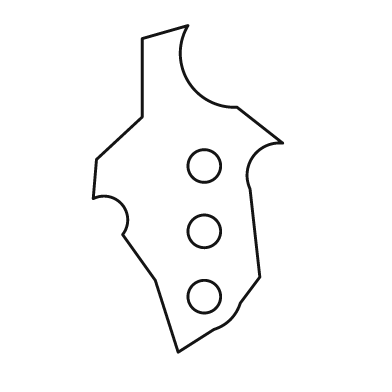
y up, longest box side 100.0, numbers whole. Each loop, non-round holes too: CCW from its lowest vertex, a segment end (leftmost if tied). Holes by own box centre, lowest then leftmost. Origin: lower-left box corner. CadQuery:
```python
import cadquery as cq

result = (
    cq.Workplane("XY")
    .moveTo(26.0, 0.0)
    .lineTo(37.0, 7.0)
    .threePointArc((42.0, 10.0), (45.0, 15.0))
    .lineTo(51.0, 23.0)
    .lineTo(48.0, 50.0)
    .threePointArc((49.0, 60.0), (58.0, 64.0))
    .lineTo(44.0, 75.0)
    .threePointArc((29.0, 83.0), (29.0, 100.0))
    .lineTo(15.0, 96.0)
    .lineTo(15.0, 72.0)
    .lineTo(1.0, 59.0)
    .lineTo(0.0, 47.0)
    .threePointArc((9.0, 45.0), (9.0, 36.0))
    .lineTo(19.0, 22.0)
    .close()
    .moveTo(34.0, 17.0)
    .circle(5.0)
    .moveTo(34.0, 37.0)
    .circle(5.0)
    .moveTo(34.0, 57.0)
    .circle(5.0)
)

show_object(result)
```